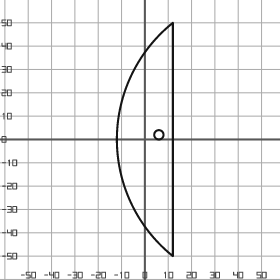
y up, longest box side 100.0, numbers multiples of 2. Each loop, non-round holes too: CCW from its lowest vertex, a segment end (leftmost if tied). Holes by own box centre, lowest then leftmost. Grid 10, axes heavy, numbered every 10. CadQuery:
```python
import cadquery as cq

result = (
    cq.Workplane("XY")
    .moveTo(12.0, -50.0)
    .lineTo(12.0, 50.0)
    .threePointArc((-12.0, 0.0), (12.0, -50.0))
    .close()
    .moveTo(6.0, 2.0)
    .circle(2.0)
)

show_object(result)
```